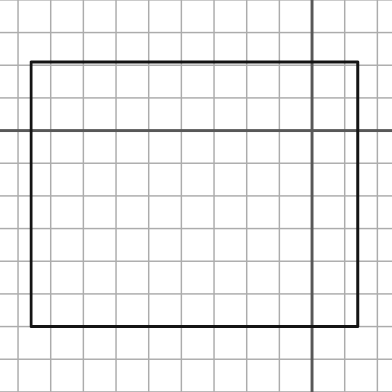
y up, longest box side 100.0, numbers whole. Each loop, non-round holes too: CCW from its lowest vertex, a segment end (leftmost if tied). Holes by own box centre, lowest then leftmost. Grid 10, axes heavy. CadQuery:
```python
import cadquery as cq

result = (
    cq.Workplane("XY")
    .moveTo(-86.0, -60.0)
    .lineTo(14.0, -60.0)
    .lineTo(14.0, 21.0)
    .lineTo(-86.0, 21.0)
    .close()
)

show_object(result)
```